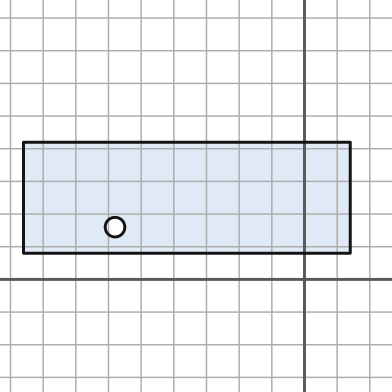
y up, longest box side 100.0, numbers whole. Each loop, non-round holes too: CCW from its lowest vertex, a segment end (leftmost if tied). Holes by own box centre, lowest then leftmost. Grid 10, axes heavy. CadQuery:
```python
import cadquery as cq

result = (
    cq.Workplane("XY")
    .moveTo(-86.0, 8.0)
    .lineTo(14.0, 8.0)
    .lineTo(14.0, 42.0)
    .lineTo(-86.0, 42.0)
    .close()
    .moveTo(-58.0, 16.0)
    .circle(3.0)
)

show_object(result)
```